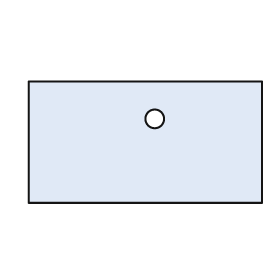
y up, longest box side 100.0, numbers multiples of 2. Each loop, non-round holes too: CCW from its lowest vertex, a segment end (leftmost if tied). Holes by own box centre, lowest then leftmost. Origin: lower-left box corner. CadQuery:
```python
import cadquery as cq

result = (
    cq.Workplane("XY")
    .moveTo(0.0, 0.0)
    .lineTo(100.0, 0.0)
    .lineTo(100.0, 52.0)
    .lineTo(0.0, 52.0)
    .close()
    .moveTo(54.0, 36.0)
    .circle(4.0)
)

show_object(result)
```